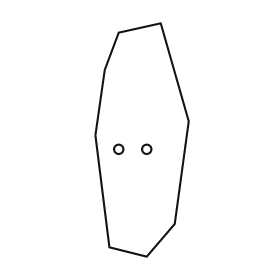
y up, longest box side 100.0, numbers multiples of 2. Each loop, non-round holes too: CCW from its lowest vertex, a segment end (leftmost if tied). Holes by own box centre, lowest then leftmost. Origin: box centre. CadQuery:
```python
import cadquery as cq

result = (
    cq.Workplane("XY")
    .moveTo(2.0, -50.0)
    .lineTo(14.0, -36.0)
    .lineTo(20.0, 8.0)
    .lineTo(8.0, 50.0)
    .lineTo(-10.0, 46.0)
    .lineTo(-16.0, 30.0)
    .lineTo(-20.0, 2.0)
    .lineTo(-14.0, -46.0)
    .close()
    .moveTo(-10.0, -4.0)
    .circle(2.0)
    .moveTo(2.0, -4.0)
    .circle(2.0)
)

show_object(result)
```